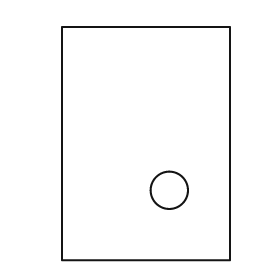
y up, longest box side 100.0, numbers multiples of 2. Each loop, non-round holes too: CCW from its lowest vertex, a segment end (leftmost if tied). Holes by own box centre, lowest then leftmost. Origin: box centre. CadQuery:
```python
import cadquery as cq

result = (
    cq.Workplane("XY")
    .moveTo(-36.0, -50.0)
    .lineTo(36.0, -50.0)
    .lineTo(36.0, 50.0)
    .lineTo(-36.0, 50.0)
    .close()
    .moveTo(10.0, -20.0)
    .circle(8.0)
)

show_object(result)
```